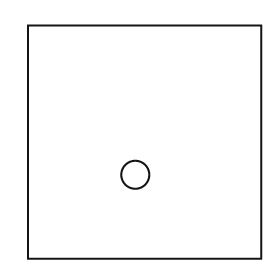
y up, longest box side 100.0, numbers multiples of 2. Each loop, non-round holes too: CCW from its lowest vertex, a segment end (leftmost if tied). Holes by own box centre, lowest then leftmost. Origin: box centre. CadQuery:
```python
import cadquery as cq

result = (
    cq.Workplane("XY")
    .moveTo(-50.0, -50.0)
    .lineTo(50.0, -50.0)
    .lineTo(50.0, 50.0)
    .lineTo(-50.0, 50.0)
    .close()
    .moveTo(-4.0, -14.0)
    .circle(6.0)
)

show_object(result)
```